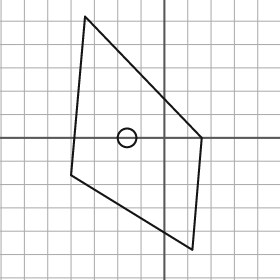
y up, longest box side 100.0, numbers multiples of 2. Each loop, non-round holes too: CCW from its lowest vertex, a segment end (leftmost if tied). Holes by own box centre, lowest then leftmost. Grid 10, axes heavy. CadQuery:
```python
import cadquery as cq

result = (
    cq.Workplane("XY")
    .moveTo(12.0, -48.0)
    .lineTo(16.0, 0.0)
    .lineTo(-34.0, 52.0)
    .lineTo(-40.0, -16.0)
    .close()
    .moveTo(-16.0, 0.0)
    .circle(4.0)
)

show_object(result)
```